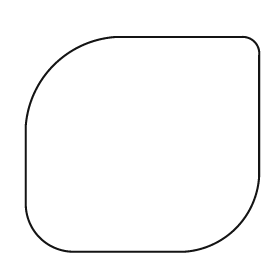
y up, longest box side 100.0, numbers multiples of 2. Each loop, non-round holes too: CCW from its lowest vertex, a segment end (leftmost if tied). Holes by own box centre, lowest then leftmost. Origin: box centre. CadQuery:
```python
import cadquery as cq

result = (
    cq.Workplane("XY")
    .moveTo(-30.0, -46.0)
    .lineTo(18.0, -46.0)
    .threePointArc((40.0, -36.0), (50.0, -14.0))
    .lineTo(50.0, 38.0)
    .threePointArc((48.0, 44.0), (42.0, 46.0))
    .lineTo(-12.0, 46.0)
    .threePointArc((-38.0, 34.0), (-50.0, 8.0))
    .lineTo(-50.0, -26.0)
    .threePointArc((-44.0, -40.0), (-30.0, -46.0))
    .close()
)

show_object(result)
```